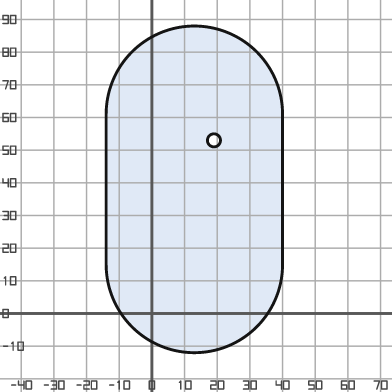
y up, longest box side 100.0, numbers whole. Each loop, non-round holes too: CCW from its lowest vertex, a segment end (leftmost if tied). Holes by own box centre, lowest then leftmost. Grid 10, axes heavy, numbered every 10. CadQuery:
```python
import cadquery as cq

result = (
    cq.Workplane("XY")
    .moveTo(-14.0, 15.0)
    .threePointArc((13.0, -12.0), (40.0, 15.0))
    .lineTo(40.0, 61.0)
    .threePointArc((13.0, 88.0), (-14.0, 61.0))
    .close()
    .moveTo(19.0, 53.0)
    .circle(2.0)
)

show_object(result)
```